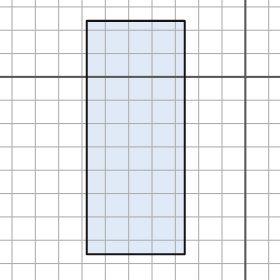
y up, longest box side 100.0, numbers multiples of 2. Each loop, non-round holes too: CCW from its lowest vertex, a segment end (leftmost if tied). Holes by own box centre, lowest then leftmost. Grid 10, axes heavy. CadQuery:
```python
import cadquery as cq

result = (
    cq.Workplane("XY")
    .moveTo(-68.0, -76.0)
    .lineTo(-26.0, -76.0)
    .lineTo(-26.0, 24.0)
    .lineTo(-68.0, 24.0)
    .close()
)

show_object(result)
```